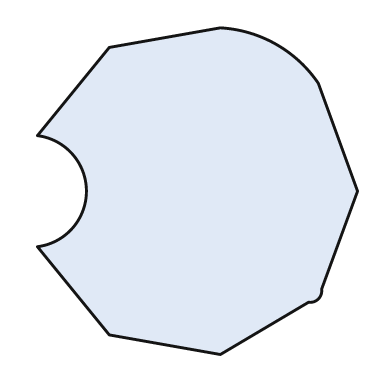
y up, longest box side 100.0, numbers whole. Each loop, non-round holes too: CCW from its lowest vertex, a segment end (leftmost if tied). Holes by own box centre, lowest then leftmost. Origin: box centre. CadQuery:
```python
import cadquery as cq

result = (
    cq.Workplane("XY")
    .moveTo(7.0, -50.0)
    .lineTo(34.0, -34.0)
    .threePointArc((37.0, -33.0), (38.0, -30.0))
    .lineTo(49.0, 0.0)
    .lineTo(37.0, 33.0)
    .threePointArc((24.0, 45.0), (7.0, 50.0))
    .lineTo(-27.0, 44.0)
    .lineTo(-49.0, 17.0)
    .threePointArc((-34.0, 0.0), (-49.0, -17.0))
    .lineTo(-27.0, -44.0)
    .close()
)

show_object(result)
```